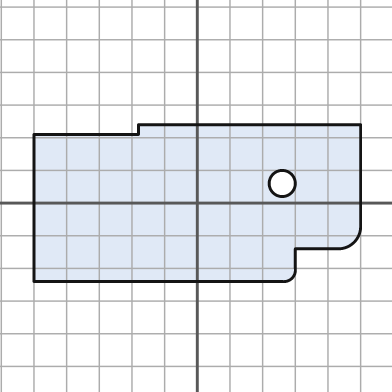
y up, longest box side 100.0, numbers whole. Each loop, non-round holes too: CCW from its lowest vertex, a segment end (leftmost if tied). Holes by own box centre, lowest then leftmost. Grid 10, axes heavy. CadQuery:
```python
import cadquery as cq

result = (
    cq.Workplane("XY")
    .moveTo(-50.0, -24.0)
    .lineTo(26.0, -24.0)
    .threePointArc((29.0, -23.0), (30.0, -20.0))
    .lineTo(30.0, -14.0)
    .lineTo(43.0, -14.0)
    .threePointArc((48.0, -12.0), (50.0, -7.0))
    .lineTo(50.0, 24.0)
    .lineTo(-18.0, 24.0)
    .lineTo(-18.0, 21.0)
    .lineTo(-50.0, 21.0)
    .close()
    .moveTo(26.0, 6.0)
    .circle(4.0)
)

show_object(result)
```